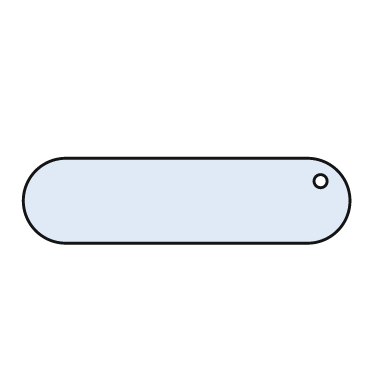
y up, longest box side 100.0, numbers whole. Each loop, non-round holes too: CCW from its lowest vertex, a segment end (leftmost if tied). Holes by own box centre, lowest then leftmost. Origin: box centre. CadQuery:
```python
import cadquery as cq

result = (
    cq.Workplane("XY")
    .moveTo(-37.0, -13.0)
    .lineTo(37.0, -13.0)
    .threePointArc((50.0, 0.0), (37.0, 13.0))
    .lineTo(-37.0, 13.0)
    .threePointArc((-50.0, 0.0), (-37.0, -13.0))
    .close()
    .moveTo(41.0, 6.0)
    .circle(2.0)
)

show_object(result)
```